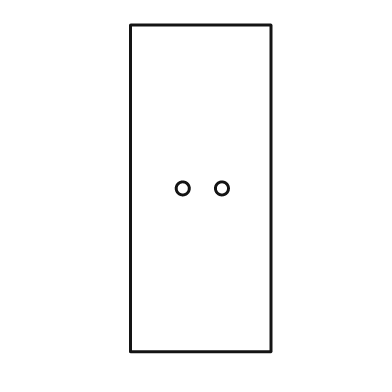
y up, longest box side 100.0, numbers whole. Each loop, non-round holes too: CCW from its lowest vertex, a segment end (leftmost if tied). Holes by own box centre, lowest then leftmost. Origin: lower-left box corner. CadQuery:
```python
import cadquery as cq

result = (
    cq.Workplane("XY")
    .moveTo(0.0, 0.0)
    .lineTo(43.0, 0.0)
    .lineTo(43.0, 100.0)
    .lineTo(0.0, 100.0)
    .close()
    .moveTo(16.0, 50.0)
    .circle(2.0)
    .moveTo(28.0, 50.0)
    .circle(2.0)
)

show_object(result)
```